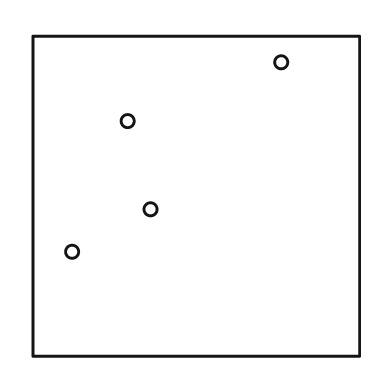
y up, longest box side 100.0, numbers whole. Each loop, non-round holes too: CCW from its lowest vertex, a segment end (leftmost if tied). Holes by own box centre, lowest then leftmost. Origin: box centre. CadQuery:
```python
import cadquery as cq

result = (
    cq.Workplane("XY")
    .moveTo(-50.0, -49.0)
    .lineTo(50.0, -49.0)
    .lineTo(50.0, 49.0)
    .lineTo(-50.0, 49.0)
    .close()
    .moveTo(-38.0, -17.0)
    .circle(2.0)
    .moveTo(-14.0, -4.0)
    .circle(2.0)
    .moveTo(-21.0, 23.0)
    .circle(2.0)
    .moveTo(26.0, 41.0)
    .circle(2.0)
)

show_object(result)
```